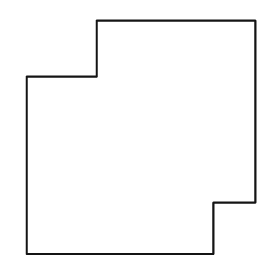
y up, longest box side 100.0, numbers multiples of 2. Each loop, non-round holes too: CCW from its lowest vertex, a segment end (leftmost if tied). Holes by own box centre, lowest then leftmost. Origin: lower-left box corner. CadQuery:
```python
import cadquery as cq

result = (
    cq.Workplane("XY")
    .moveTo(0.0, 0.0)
    .lineTo(80.0, 0.0)
    .lineTo(80.0, 22.0)
    .lineTo(98.0, 22.0)
    .lineTo(98.0, 100.0)
    .lineTo(30.0, 100.0)
    .lineTo(30.0, 76.0)
    .lineTo(0.0, 76.0)
    .close()
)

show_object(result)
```